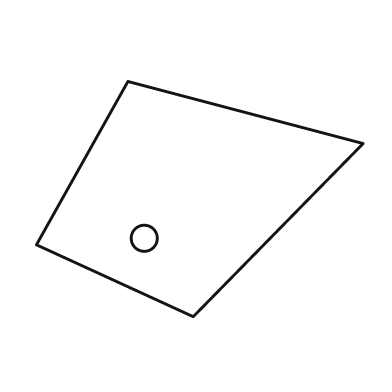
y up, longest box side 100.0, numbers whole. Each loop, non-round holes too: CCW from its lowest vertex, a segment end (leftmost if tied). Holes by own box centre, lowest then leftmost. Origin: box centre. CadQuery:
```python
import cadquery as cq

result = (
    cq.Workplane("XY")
    .moveTo(-2.0, -36.0)
    .lineTo(50.0, 17.0)
    .lineTo(-22.0, 36.0)
    .lineTo(-50.0, -14.0)
    .close()
    .moveTo(-17.0, -12.0)
    .circle(4.0)
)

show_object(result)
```